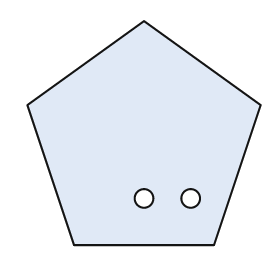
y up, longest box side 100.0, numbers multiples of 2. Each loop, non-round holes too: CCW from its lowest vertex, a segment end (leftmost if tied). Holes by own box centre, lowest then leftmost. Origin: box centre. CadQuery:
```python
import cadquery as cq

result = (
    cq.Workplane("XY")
    .moveTo(-30.0, -48.0)
    .lineTo(30.0, -48.0)
    .lineTo(50.0, 12.0)
    .lineTo(0.0, 48.0)
    .lineTo(-50.0, 12.0)
    .close()
    .moveTo(0.0, -28.0)
    .circle(4.0)
    .moveTo(20.0, -28.0)
    .circle(4.0)
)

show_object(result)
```